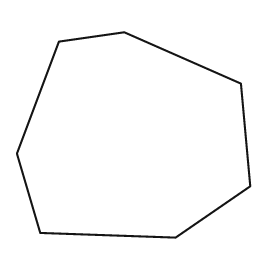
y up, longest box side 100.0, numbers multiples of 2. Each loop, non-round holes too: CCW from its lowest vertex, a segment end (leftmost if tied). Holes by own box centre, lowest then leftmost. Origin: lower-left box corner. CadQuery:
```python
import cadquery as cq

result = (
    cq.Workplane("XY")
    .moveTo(68.0, 0.0)
    .lineTo(100.0, 22.0)
    .lineTo(96.0, 66.0)
    .lineTo(46.0, 88.0)
    .lineTo(18.0, 84.0)
    .lineTo(0.0, 36.0)
    .lineTo(10.0, 2.0)
    .close()
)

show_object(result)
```